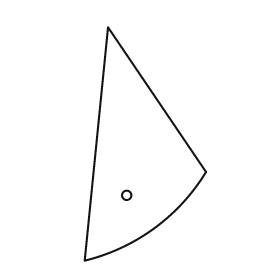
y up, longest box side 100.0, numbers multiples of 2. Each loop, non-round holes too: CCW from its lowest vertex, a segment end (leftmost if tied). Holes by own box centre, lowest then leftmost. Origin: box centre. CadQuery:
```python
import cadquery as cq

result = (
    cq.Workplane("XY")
    .moveTo(-26.0, -50.0)
    .threePointArc((4.0, -36.0), (26.0, -12.0))
    .lineTo(-16.0, 50.0)
    .close()
    .moveTo(-8.0, -22.0)
    .circle(2.0)
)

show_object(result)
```